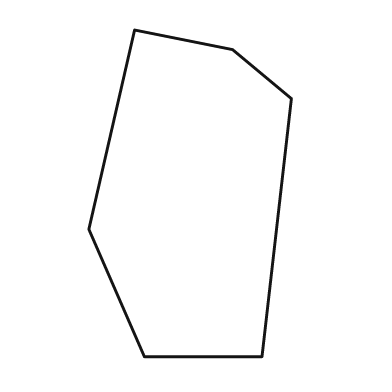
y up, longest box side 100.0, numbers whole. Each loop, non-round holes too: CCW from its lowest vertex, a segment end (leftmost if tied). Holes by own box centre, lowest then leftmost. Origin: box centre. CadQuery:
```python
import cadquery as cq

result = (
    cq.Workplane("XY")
    .moveTo(-14.0, -50.0)
    .lineTo(22.0, -50.0)
    .lineTo(31.0, 29.0)
    .lineTo(13.0, 44.0)
    .lineTo(-17.0, 50.0)
    .lineTo(-31.0, -11.0)
    .close()
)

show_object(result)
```